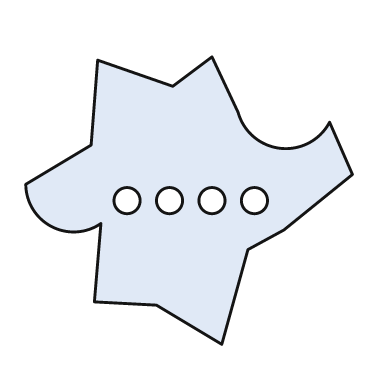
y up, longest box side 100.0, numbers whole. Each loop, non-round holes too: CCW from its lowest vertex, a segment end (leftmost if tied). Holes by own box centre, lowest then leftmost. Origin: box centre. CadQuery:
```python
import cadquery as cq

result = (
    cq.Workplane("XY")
    .moveTo(10.0, -44.0)
    .lineTo(18.0, -15.0)
    .lineTo(29.0, -9.0)
    .lineTo(50.0, 8.0)
    .lineTo(43.0, 24.0)
    .threePointArc((28.0, 16.0), (15.0, 27.0))
    .lineTo(7.0, 44.0)
    .lineTo(-5.0, 35.0)
    .lineTo(-28.0, 43.0)
    .lineTo(-30.0, 17.0)
    .lineTo(-50.0, 5.0)
    .threePointArc((-42.0, -8.0), (-27.0, -7.0))
    .lineTo(-29.0, -31.0)
    .lineTo(-10.0, -32.0)
    .close()
    .moveTo(-19.0, 0.0)
    .circle(4.0)
    .moveTo(-6.0, 0.0)
    .circle(4.0)
    .moveTo(7.0, 0.0)
    .circle(4.0)
    .moveTo(20.0, 0.0)
    .circle(4.0)
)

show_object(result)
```